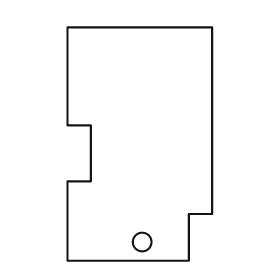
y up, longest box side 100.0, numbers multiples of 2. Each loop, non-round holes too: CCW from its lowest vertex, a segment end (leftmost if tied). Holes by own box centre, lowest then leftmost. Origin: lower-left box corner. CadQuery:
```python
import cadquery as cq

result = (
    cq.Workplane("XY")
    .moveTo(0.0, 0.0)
    .lineTo(52.0, 0.0)
    .lineTo(52.0, 20.0)
    .lineTo(62.0, 20.0)
    .lineTo(62.0, 100.0)
    .lineTo(0.0, 100.0)
    .lineTo(0.0, 58.0)
    .lineTo(10.0, 58.0)
    .lineTo(10.0, 34.0)
    .lineTo(0.0, 34.0)
    .close()
    .moveTo(32.0, 8.0)
    .circle(4.0)
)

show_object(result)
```